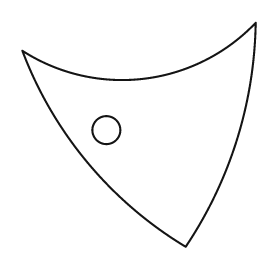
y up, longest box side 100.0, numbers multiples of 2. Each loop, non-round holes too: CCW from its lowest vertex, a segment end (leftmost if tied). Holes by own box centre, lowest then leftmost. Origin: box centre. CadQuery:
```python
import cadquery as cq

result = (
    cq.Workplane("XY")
    .moveTo(20.0, -48.0)
    .threePointArc((42.0, -2.0), (50.0, 48.0))
    .threePointArc((2.0, 24.0), (-50.0, 36.0))
    .threePointArc((-22.0, -12.0), (20.0, -48.0))
    .close()
    .moveTo(-14.0, 2.0)
    .circle(6.0)
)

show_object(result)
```